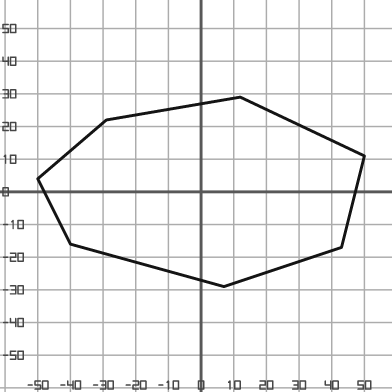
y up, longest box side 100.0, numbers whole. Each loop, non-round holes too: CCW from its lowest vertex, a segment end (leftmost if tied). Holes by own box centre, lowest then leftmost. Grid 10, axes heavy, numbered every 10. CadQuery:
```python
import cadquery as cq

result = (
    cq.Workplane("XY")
    .moveTo(7.0, -29.0)
    .lineTo(43.0, -17.0)
    .lineTo(50.0, 11.0)
    .lineTo(12.0, 29.0)
    .lineTo(-29.0, 22.0)
    .lineTo(-50.0, 4.0)
    .lineTo(-40.0, -16.0)
    .close()
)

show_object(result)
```